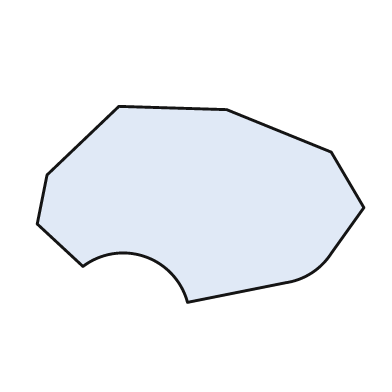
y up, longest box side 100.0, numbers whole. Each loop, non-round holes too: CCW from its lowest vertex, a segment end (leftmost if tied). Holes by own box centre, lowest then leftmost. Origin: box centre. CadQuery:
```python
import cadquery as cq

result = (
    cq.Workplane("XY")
    .moveTo(-4.0, -30.0)
    .lineTo(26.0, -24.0)
    .threePointArc((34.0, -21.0), (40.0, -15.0))
    .lineTo(50.0, -1.0)
    .lineTo(40.0, 16.0)
    .lineTo(8.0, 29.0)
    .lineTo(-25.0, 30.0)
    .lineTo(-47.0, 9.0)
    .lineTo(-50.0, -6.0)
    .lineTo(-36.0, -19.0)
    .threePointArc((-17.0, -16.0), (-4.0, -30.0))
    .close()
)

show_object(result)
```